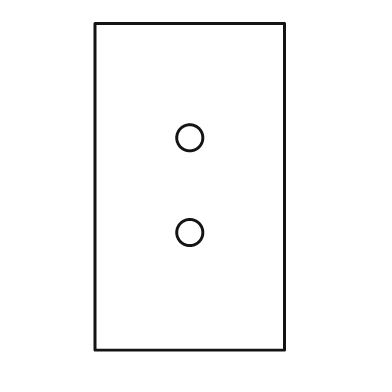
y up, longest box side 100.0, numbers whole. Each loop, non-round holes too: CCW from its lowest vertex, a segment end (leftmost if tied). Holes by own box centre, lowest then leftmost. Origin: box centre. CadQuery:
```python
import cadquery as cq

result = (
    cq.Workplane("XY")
    .moveTo(-29.0, -50.0)
    .lineTo(29.0, -50.0)
    .lineTo(29.0, 50.0)
    .lineTo(-29.0, 50.0)
    .close()
    .moveTo(0.0, -14.0)
    .circle(4.0)
    .moveTo(0.0, 15.0)
    .circle(4.0)
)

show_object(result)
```